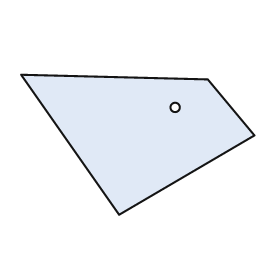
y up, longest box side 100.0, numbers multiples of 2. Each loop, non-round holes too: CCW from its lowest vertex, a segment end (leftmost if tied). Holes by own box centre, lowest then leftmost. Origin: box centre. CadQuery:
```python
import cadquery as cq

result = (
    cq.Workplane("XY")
    .moveTo(-8.0, -30.0)
    .lineTo(50.0, 4.0)
    .lineTo(30.0, 28.0)
    .lineTo(-50.0, 30.0)
    .close()
    .moveTo(16.0, 16.0)
    .circle(2.0)
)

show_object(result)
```